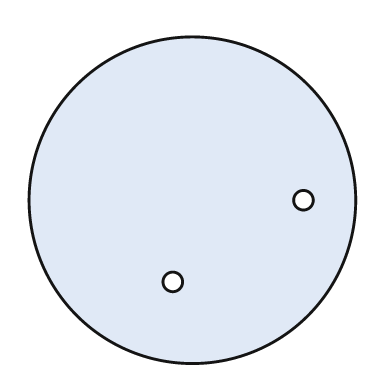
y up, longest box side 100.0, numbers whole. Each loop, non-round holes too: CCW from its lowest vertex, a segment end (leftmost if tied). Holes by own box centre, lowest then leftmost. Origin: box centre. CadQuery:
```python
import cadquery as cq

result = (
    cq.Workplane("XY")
    .moveTo(0.0, 0.0)
    .circle(50.0)
    .moveTo(-6.0, -25.0)
    .circle(3.0)
    .moveTo(34.0, 0.0)
    .circle(3.0)
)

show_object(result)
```